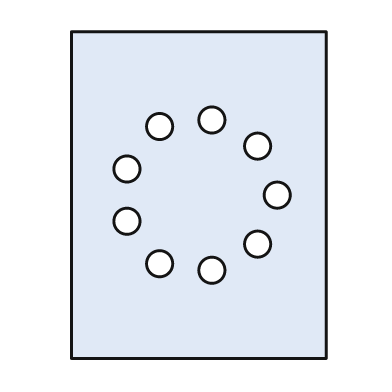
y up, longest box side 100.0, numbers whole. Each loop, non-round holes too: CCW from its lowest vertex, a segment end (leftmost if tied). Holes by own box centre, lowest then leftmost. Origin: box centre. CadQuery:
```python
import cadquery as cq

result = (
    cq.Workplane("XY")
    .moveTo(-39.0, -50.0)
    .lineTo(39.0, -50.0)
    .lineTo(39.0, 50.0)
    .lineTo(-39.0, 50.0)
    .close()
    .moveTo(4.0, -23.0)
    .circle(4.0)
    .moveTo(-12.0, -21.0)
    .circle(4.0)
    .moveTo(18.0, -15.0)
    .circle(4.0)
    .moveTo(-22.0, -8.0)
    .circle(4.0)
    .moveTo(24.0, 0.0)
    .circle(4.0)
    .moveTo(-22.0, 8.0)
    .circle(4.0)
    .moveTo(18.0, 15.0)
    .circle(4.0)
    .moveTo(-12.0, 21.0)
    .circle(4.0)
    .moveTo(4.0, 23.0)
    .circle(4.0)
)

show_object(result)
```